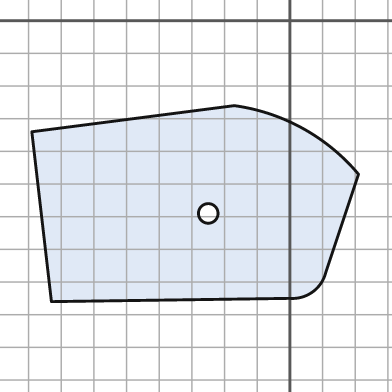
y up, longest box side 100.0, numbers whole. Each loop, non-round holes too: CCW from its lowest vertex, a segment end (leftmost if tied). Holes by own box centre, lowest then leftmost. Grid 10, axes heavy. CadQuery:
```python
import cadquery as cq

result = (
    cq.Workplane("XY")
    .moveTo(-73.0, -86.0)
    .lineTo(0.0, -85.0)
    .threePointArc((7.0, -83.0), (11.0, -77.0))
    .lineTo(21.0, -47.0)
    .threePointArc((4.0, -33.0), (-17.0, -26.0))
    .lineTo(-79.0, -34.0)
    .close()
    .moveTo(-25.0, -59.0)
    .circle(3.0)
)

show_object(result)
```